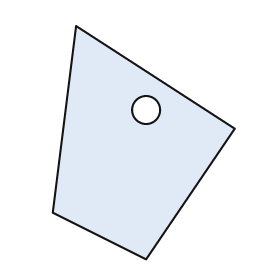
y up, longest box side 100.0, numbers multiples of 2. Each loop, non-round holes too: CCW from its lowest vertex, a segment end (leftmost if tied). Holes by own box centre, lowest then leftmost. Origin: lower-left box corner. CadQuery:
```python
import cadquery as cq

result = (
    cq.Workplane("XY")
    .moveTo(40.0, 0.0)
    .lineTo(78.0, 56.0)
    .lineTo(10.0, 100.0)
    .lineTo(0.0, 20.0)
    .close()
    .moveTo(40.0, 64.0)
    .circle(6.0)
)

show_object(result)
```